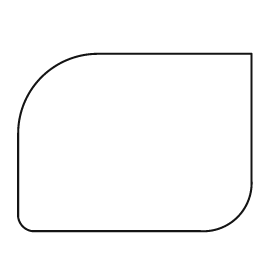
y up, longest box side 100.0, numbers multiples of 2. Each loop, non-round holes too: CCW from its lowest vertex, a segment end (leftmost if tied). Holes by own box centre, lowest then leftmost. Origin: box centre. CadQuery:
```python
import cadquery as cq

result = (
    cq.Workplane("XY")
    .moveTo(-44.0, -38.0)
    .lineTo(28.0, -38.0)
    .threePointArc((44.0, -32.0), (50.0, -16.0))
    .lineTo(50.0, 38.0)
    .lineTo(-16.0, 38.0)
    .threePointArc((-40.0, 28.0), (-50.0, 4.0))
    .lineTo(-50.0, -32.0)
    .threePointArc((-48.0, -36.0), (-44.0, -38.0))
    .close()
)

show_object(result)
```